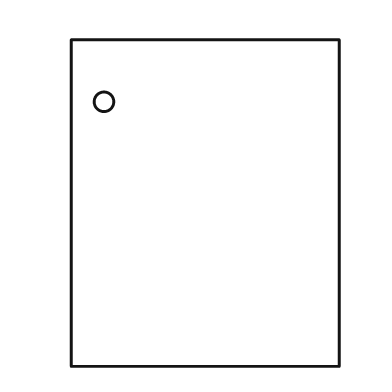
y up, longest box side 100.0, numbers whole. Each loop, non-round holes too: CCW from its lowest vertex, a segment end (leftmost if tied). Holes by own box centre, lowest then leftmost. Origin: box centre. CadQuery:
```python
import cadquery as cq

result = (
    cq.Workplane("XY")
    .moveTo(-41.0, -50.0)
    .lineTo(41.0, -50.0)
    .lineTo(41.0, 50.0)
    .lineTo(-41.0, 50.0)
    .close()
    .moveTo(-31.0, 31.0)
    .circle(3.0)
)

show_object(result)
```